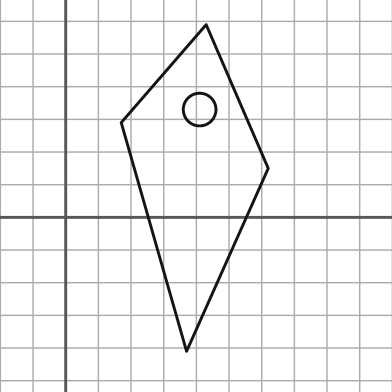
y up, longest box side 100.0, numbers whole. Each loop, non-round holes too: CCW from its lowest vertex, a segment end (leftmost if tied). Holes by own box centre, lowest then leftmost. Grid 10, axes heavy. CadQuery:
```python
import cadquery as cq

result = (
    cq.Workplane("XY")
    .moveTo(37.0, -41.0)
    .lineTo(62.0, 15.0)
    .lineTo(43.0, 59.0)
    .lineTo(17.0, 29.0)
    .close()
    .moveTo(41.0, 33.0)
    .circle(5.0)
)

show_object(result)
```